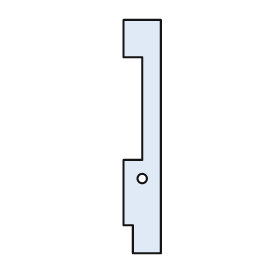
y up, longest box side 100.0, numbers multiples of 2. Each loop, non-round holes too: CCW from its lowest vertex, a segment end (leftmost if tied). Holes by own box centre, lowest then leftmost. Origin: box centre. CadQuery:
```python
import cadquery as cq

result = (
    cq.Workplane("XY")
    .moveTo(-4.0, -50.0)
    .lineTo(8.0, -50.0)
    .lineTo(8.0, 50.0)
    .lineTo(-8.0, 50.0)
    .lineTo(-8.0, 34.0)
    .lineTo(0.0, 34.0)
    .lineTo(0.0, -10.0)
    .lineTo(-8.0, -10.0)
    .lineTo(-8.0, -38.0)
    .lineTo(-4.0, -38.0)
    .close()
    .moveTo(0.0, -18.0)
    .circle(2.0)
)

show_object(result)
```